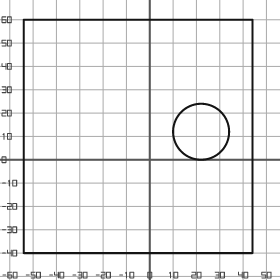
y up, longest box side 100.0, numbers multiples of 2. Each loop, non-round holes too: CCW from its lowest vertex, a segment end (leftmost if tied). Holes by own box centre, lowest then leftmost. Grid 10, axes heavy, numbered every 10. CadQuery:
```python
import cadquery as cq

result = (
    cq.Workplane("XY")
    .moveTo(-54.0, -40.0)
    .lineTo(44.0, -40.0)
    .lineTo(44.0, 60.0)
    .lineTo(-54.0, 60.0)
    .close()
    .moveTo(22.0, 12.0)
    .circle(12.0)
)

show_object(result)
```